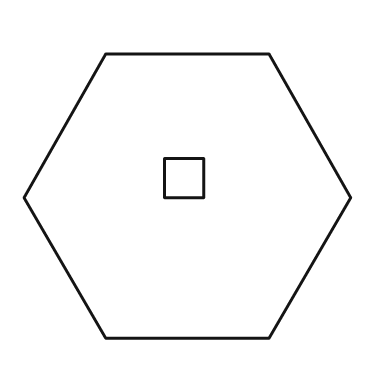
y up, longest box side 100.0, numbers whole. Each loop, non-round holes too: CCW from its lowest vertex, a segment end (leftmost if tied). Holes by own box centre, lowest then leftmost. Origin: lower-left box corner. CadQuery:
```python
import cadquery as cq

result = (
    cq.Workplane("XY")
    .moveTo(25.0, 0.0)
    .lineTo(75.0, 0.0)
    .lineTo(100.0, 43.0)
    .lineTo(75.0, 87.0)
    .lineTo(25.0, 87.0)
    .lineTo(0.0, 43.0)
    .close()
    .moveTo(43.0, 43.0)
    .lineTo(55.0, 43.0)
    .lineTo(55.0, 55.0)
    .lineTo(43.0, 55.0)
    .close()
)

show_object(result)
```